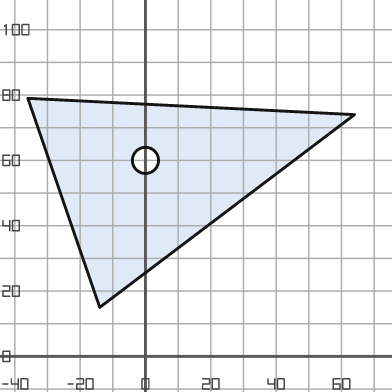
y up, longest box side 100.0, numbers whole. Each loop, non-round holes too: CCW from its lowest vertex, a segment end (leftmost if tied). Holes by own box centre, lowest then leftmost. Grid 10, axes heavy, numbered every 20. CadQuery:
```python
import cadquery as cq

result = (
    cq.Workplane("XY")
    .moveTo(-14.0, 15.0)
    .lineTo(64.0, 74.0)
    .lineTo(-36.0, 79.0)
    .close()
    .moveTo(0.0, 60.0)
    .circle(4.0)
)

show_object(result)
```